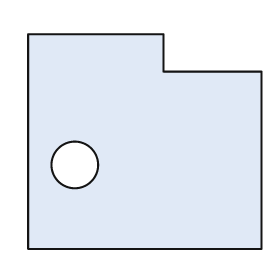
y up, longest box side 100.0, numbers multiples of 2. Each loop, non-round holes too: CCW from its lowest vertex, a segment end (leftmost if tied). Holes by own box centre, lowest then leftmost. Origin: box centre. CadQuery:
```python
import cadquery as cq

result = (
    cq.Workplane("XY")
    .moveTo(-50.0, -46.0)
    .lineTo(50.0, -46.0)
    .lineTo(50.0, 30.0)
    .lineTo(8.0, 30.0)
    .lineTo(8.0, 46.0)
    .lineTo(-50.0, 46.0)
    .close()
    .moveTo(-30.0, -10.0)
    .circle(10.0)
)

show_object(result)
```